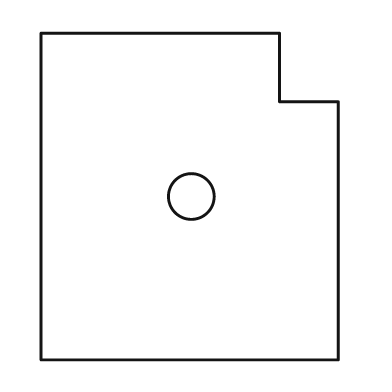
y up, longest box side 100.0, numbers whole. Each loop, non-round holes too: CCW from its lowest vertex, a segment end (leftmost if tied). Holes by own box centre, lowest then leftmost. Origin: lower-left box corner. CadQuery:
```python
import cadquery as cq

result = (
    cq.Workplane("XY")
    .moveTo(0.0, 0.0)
    .lineTo(91.0, 0.0)
    .lineTo(91.0, 79.0)
    .lineTo(73.0, 79.0)
    .lineTo(73.0, 100.0)
    .lineTo(0.0, 100.0)
    .close()
    .moveTo(46.0, 50.0)
    .circle(7.0)
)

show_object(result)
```